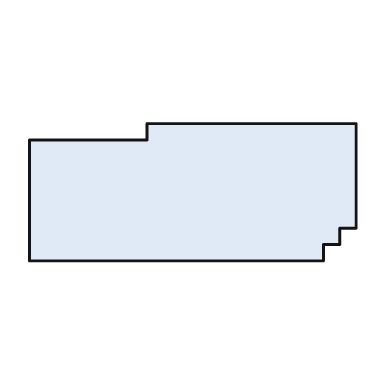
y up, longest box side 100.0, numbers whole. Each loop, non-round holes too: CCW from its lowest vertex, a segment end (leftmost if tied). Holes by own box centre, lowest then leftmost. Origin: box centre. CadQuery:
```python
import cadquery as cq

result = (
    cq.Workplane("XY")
    .moveTo(-50.0, -21.0)
    .lineTo(40.0, -21.0)
    .lineTo(40.0, -16.0)
    .lineTo(45.0, -16.0)
    .lineTo(45.0, -11.0)
    .lineTo(50.0, -11.0)
    .lineTo(50.0, 21.0)
    .lineTo(-14.0, 21.0)
    .lineTo(-14.0, 16.0)
    .lineTo(-50.0, 16.0)
    .close()
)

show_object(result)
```